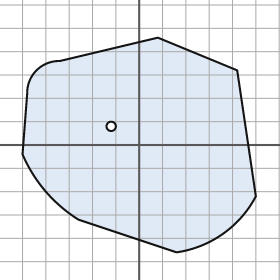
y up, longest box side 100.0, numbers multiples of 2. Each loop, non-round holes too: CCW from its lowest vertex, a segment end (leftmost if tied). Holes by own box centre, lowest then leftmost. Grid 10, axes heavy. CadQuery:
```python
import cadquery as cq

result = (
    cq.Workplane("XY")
    .moveTo(16.0, -46.0)
    .threePointArc((36.0, -38.0), (50.0, -22.0))
    .lineTo(42.0, 32.0)
    .lineTo(8.0, 46.0)
    .lineTo(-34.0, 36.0)
    .threePointArc((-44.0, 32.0), (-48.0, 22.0))
    .lineTo(-50.0, -4.0)
    .threePointArc((-40.0, -20.0), (-26.0, -32.0))
    .close()
    .moveTo(-12.0, 8.0)
    .circle(2.0)
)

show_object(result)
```